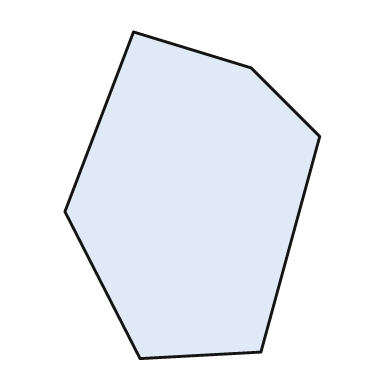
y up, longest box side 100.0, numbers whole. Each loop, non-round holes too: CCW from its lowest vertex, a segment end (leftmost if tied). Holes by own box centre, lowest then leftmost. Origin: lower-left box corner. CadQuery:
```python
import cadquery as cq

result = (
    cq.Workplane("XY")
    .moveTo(23.0, 0.0)
    .lineTo(60.0, 2.0)
    .lineTo(78.0, 68.0)
    .lineTo(57.0, 89.0)
    .lineTo(21.0, 100.0)
    .lineTo(0.0, 45.0)
    .close()
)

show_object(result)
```